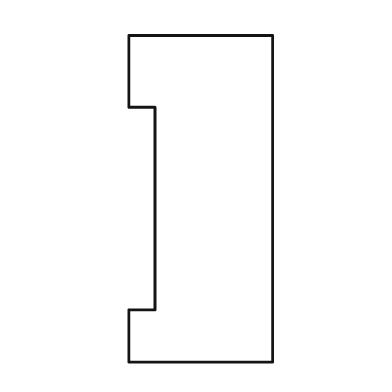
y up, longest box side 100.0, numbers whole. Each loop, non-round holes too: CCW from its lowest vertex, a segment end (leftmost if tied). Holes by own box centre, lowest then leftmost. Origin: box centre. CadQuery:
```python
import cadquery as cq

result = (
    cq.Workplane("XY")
    .moveTo(-22.0, -50.0)
    .lineTo(22.0, -50.0)
    .lineTo(22.0, 50.0)
    .lineTo(-22.0, 50.0)
    .lineTo(-22.0, 28.0)
    .lineTo(-14.0, 28.0)
    .lineTo(-14.0, -34.0)
    .lineTo(-22.0, -34.0)
    .close()
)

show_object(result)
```